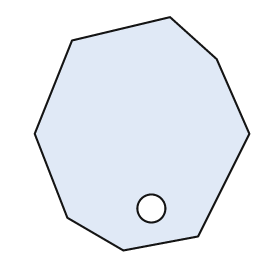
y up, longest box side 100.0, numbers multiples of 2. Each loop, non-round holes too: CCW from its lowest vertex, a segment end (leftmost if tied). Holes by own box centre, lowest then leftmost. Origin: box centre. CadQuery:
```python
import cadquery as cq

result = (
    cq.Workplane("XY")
    .moveTo(-8.0, -50.0)
    .lineTo(24.0, -44.0)
    .lineTo(46.0, 0.0)
    .lineTo(32.0, 32.0)
    .lineTo(12.0, 50.0)
    .lineTo(-30.0, 40.0)
    .lineTo(-46.0, 0.0)
    .lineTo(-32.0, -36.0)
    .close()
    .moveTo(4.0, -32.0)
    .circle(6.0)
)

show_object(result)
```